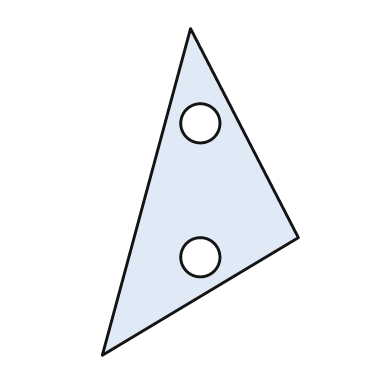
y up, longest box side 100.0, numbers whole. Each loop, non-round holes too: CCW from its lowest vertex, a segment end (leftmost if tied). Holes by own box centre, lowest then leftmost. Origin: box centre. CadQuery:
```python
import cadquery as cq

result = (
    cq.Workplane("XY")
    .moveTo(-30.0, -50.0)
    .lineTo(30.0, -14.0)
    .lineTo(-3.0, 50.0)
    .close()
    .moveTo(0.0, -20.0)
    .circle(6.0)
    .moveTo(0.0, 21.0)
    .circle(6.0)
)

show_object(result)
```